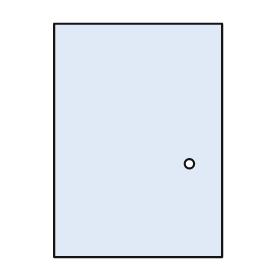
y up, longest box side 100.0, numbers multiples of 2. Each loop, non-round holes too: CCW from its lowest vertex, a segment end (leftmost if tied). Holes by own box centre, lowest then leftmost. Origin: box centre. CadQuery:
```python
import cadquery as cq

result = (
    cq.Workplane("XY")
    .moveTo(-36.0, -50.0)
    .lineTo(36.0, -50.0)
    .lineTo(36.0, 50.0)
    .lineTo(-36.0, 50.0)
    .close()
    .moveTo(22.0, -10.0)
    .circle(2.0)
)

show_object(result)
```